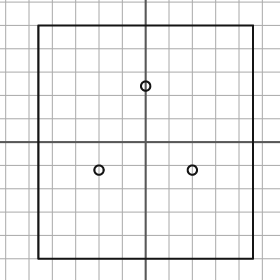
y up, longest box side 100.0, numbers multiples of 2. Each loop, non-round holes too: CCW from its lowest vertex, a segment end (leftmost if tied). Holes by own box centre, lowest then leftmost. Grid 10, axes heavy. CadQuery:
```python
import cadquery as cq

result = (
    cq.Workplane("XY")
    .moveTo(-46.0, -50.0)
    .lineTo(46.0, -50.0)
    .lineTo(46.0, 50.0)
    .lineTo(-46.0, 50.0)
    .close()
    .moveTo(-20.0, -12.0)
    .circle(2.0)
    .moveTo(20.0, -12.0)
    .circle(2.0)
    .moveTo(0.0, 24.0)
    .circle(2.0)
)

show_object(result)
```